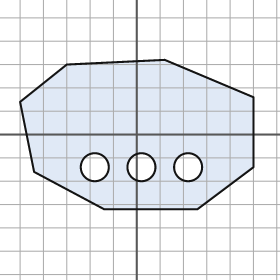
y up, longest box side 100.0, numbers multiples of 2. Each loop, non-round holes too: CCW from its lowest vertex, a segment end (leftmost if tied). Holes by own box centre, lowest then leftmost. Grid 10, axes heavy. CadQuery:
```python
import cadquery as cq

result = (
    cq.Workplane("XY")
    .moveTo(-14.0, -32.0)
    .lineTo(26.0, -32.0)
    .lineTo(50.0, -14.0)
    .lineTo(50.0, 16.0)
    .lineTo(12.0, 32.0)
    .lineTo(-30.0, 30.0)
    .lineTo(-50.0, 14.0)
    .lineTo(-44.0, -16.0)
    .close()
    .moveTo(-18.0, -14.0)
    .circle(6.0)
    .moveTo(2.0, -14.0)
    .circle(6.0)
    .moveTo(22.0, -14.0)
    .circle(6.0)
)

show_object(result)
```